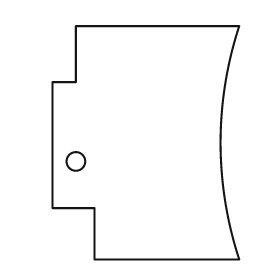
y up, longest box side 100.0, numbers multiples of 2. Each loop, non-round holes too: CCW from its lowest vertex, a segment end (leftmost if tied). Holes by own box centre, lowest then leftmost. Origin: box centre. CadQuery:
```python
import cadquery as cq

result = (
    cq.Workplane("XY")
    .moveTo(-22.0, -50.0)
    .lineTo(40.0, -50.0)
    .threePointArc((32.0, 0.0), (40.0, 50.0))
    .lineTo(-30.0, 50.0)
    .lineTo(-30.0, 26.0)
    .lineTo(-40.0, 26.0)
    .lineTo(-40.0, -28.0)
    .lineTo(-22.0, -28.0)
    .close()
    .moveTo(-30.0, -8.0)
    .circle(4.0)
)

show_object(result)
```